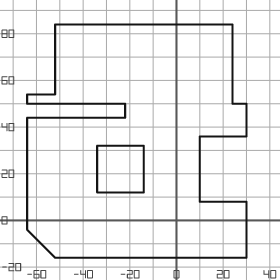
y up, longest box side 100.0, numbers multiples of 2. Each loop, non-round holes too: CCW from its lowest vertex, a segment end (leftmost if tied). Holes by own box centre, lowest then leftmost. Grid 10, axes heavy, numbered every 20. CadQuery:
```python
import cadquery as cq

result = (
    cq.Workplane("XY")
    .moveTo(-52.0, -16.0)
    .lineTo(30.0, -16.0)
    .lineTo(30.0, 8.0)
    .lineTo(10.0, 8.0)
    .lineTo(10.0, 36.0)
    .lineTo(30.0, 36.0)
    .lineTo(30.0, 50.0)
    .lineTo(24.0, 50.0)
    .lineTo(24.0, 84.0)
    .lineTo(-52.0, 84.0)
    .lineTo(-52.0, 54.0)
    .lineTo(-64.0, 54.0)
    .lineTo(-64.0, 50.0)
    .lineTo(-22.0, 50.0)
    .lineTo(-22.0, 44.0)
    .lineTo(-64.0, 44.0)
    .lineTo(-64.0, -4.0)
    .close()
    .moveTo(-34.0, 12.0)
    .lineTo(-14.0, 12.0)
    .lineTo(-14.0, 32.0)
    .lineTo(-34.0, 32.0)
    .close()
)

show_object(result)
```